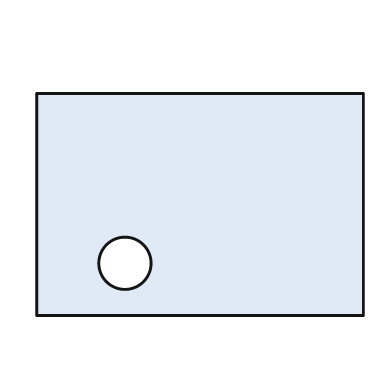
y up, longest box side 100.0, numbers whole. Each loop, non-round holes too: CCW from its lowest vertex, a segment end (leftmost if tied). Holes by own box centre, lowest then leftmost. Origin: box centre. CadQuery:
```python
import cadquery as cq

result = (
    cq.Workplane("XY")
    .moveTo(-50.0, -34.0)
    .lineTo(50.0, -34.0)
    .lineTo(50.0, 34.0)
    .lineTo(-50.0, 34.0)
    .close()
    .moveTo(-23.0, -18.0)
    .circle(8.0)
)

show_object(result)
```